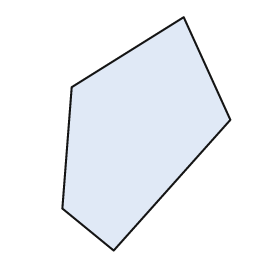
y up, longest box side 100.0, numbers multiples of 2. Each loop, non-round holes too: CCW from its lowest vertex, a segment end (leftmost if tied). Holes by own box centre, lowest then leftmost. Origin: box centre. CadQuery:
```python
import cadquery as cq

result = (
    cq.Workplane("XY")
    .moveTo(-14.0, -50.0)
    .lineTo(36.0, 6.0)
    .lineTo(16.0, 50.0)
    .lineTo(-32.0, 20.0)
    .lineTo(-36.0, -32.0)
    .close()
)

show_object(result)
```